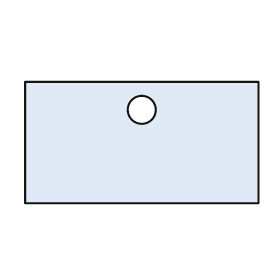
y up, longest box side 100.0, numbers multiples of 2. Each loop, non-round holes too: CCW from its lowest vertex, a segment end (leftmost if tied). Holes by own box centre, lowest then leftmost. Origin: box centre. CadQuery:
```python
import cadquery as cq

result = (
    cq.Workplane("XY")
    .moveTo(-50.0, -26.0)
    .lineTo(50.0, -26.0)
    .lineTo(50.0, 26.0)
    .lineTo(-50.0, 26.0)
    .close()
    .moveTo(0.0, 14.0)
    .circle(6.0)
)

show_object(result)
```